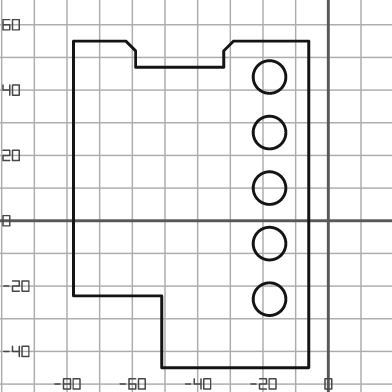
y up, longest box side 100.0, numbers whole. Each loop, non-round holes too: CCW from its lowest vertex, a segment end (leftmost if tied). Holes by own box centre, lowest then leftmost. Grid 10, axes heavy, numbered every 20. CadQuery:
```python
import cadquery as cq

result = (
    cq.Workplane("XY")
    .moveTo(-51.0, -45.0)
    .lineTo(-6.0, -45.0)
    .lineTo(-6.0, 55.0)
    .lineTo(-29.0, 55.0)
    .lineTo(-32.0, 52.0)
    .lineTo(-32.0, 47.0)
    .lineTo(-59.0, 47.0)
    .lineTo(-59.0, 52.0)
    .lineTo(-62.0, 55.0)
    .lineTo(-78.0, 55.0)
    .lineTo(-78.0, -23.0)
    .lineTo(-51.0, -23.0)
    .close()
    .moveTo(-18.0, -24.0)
    .circle(5.0)
    .moveTo(-18.0, -7.0)
    .circle(5.0)
    .moveTo(-18.0, 10.0)
    .circle(5.0)
    .moveTo(-18.0, 27.0)
    .circle(5.0)
    .moveTo(-18.0, 44.0)
    .circle(5.0)
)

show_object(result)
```